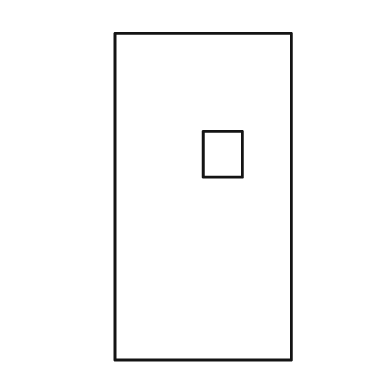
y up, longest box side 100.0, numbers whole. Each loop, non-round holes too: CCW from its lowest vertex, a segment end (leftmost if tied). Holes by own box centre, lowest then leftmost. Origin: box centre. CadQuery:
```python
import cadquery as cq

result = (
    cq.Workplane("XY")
    .moveTo(-27.0, -50.0)
    .lineTo(27.0, -50.0)
    .lineTo(27.0, 50.0)
    .lineTo(-27.0, 50.0)
    .close()
    .moveTo(0.0, 6.0)
    .lineTo(12.0, 6.0)
    .lineTo(12.0, 20.0)
    .lineTo(0.0, 20.0)
    .close()
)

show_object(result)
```